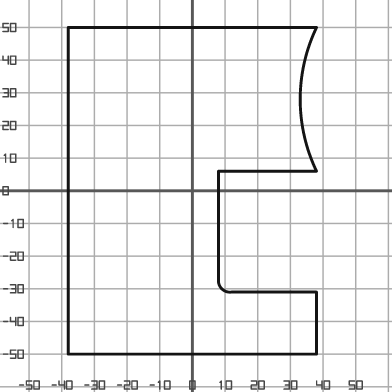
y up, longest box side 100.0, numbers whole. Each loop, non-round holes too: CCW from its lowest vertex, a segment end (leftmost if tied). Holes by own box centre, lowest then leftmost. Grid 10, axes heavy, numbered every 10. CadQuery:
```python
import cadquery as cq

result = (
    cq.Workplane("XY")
    .moveTo(-38.0, -50.0)
    .lineTo(38.0, -50.0)
    .lineTo(38.0, -31.0)
    .lineTo(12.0, -31.0)
    .threePointArc((9.0, -30.0), (8.0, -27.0))
    .lineTo(8.0, 6.0)
    .lineTo(38.0, 6.0)
    .threePointArc((33.0, 28.0), (38.0, 50.0))
    .lineTo(-38.0, 50.0)
    .close()
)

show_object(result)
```